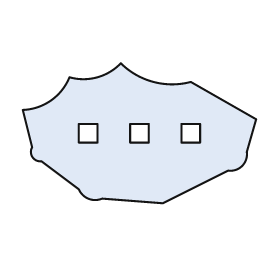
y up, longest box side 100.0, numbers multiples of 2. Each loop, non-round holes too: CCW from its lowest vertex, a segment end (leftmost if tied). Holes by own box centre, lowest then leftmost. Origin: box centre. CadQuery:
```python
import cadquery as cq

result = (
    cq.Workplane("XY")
    .moveTo(10.0, -30.0)
    .lineTo(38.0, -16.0)
    .threePointArc((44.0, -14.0), (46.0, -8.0))
    .lineTo(50.0, 6.0)
    .lineTo(22.0, 22.0)
    .threePointArc((6.0, 22.0), (-8.0, 30.0))
    .threePointArc((-18.0, 24.0), (-30.0, 24.0))
    .threePointArc((-38.0, 14.0), (-50.0, 10.0))
    .lineTo(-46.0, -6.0)
    .threePointArc((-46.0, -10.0), (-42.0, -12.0))
    .lineTo(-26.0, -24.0)
    .threePointArc((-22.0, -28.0), (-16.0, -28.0))
    .close()
    .moveTo(-26.0, -4.0)
    .lineTo(-18.0, -4.0)
    .lineTo(-18.0, 4.0)
    .lineTo(-26.0, 4.0)
    .close()
    .moveTo(-4.0, -4.0)
    .lineTo(4.0, -4.0)
    .lineTo(4.0, 4.0)
    .lineTo(-4.0, 4.0)
    .close()
    .moveTo(18.0, -4.0)
    .lineTo(26.0, -4.0)
    .lineTo(26.0, 4.0)
    .lineTo(18.0, 4.0)
    .close()
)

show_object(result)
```